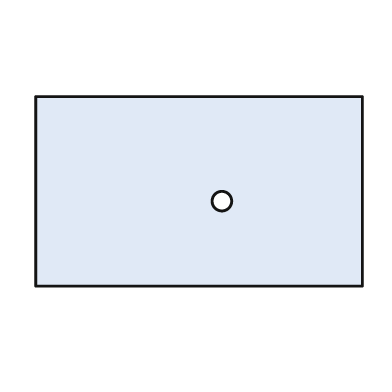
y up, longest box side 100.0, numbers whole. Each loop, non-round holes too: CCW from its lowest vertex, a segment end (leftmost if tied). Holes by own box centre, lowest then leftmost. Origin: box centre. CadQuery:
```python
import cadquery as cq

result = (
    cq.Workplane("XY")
    .moveTo(-50.0, -29.0)
    .lineTo(50.0, -29.0)
    .lineTo(50.0, 29.0)
    .lineTo(-50.0, 29.0)
    .close()
    .moveTo(7.0, -3.0)
    .circle(3.0)
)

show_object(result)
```